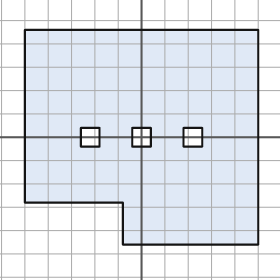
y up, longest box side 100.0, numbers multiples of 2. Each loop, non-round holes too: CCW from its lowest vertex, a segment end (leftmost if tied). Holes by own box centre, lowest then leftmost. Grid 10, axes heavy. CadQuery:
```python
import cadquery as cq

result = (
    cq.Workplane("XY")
    .moveTo(-8.0, -46.0)
    .lineTo(50.0, -46.0)
    .lineTo(50.0, 46.0)
    .lineTo(-50.0, 46.0)
    .lineTo(-50.0, -28.0)
    .lineTo(-8.0, -28.0)
    .close()
    .moveTo(-26.0, -4.0)
    .lineTo(-18.0, -4.0)
    .lineTo(-18.0, 4.0)
    .lineTo(-26.0, 4.0)
    .close()
    .moveTo(-4.0, -4.0)
    .lineTo(4.0, -4.0)
    .lineTo(4.0, 4.0)
    .lineTo(-4.0, 4.0)
    .close()
    .moveTo(18.0, -4.0)
    .lineTo(26.0, -4.0)
    .lineTo(26.0, 4.0)
    .lineTo(18.0, 4.0)
    .close()
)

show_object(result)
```